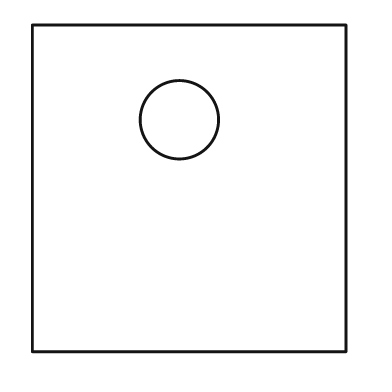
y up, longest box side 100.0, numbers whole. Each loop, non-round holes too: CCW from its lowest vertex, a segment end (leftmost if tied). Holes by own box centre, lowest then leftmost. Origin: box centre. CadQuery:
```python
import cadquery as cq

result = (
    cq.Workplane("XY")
    .moveTo(-48.0, -50.0)
    .lineTo(48.0, -50.0)
    .lineTo(48.0, 50.0)
    .lineTo(-48.0, 50.0)
    .close()
    .moveTo(-3.0, 21.0)
    .circle(12.0)
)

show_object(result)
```